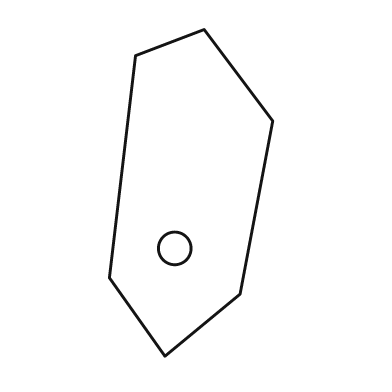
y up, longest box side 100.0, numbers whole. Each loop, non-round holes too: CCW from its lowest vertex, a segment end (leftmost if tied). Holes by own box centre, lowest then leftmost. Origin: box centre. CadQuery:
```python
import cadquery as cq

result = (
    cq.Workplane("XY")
    .moveTo(-8.0, -50.0)
    .lineTo(15.0, -31.0)
    .lineTo(25.0, 22.0)
    .lineTo(4.0, 50.0)
    .lineTo(-17.0, 42.0)
    .lineTo(-25.0, -26.0)
    .close()
    .moveTo(-5.0, -17.0)
    .circle(5.0)
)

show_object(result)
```